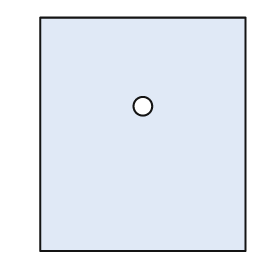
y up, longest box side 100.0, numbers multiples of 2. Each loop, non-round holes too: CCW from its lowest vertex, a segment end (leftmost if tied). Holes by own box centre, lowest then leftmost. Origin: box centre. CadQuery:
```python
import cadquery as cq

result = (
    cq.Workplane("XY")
    .moveTo(-44.0, -50.0)
    .lineTo(44.0, -50.0)
    .lineTo(44.0, 50.0)
    .lineTo(-44.0, 50.0)
    .close()
    .moveTo(0.0, 12.0)
    .circle(4.0)
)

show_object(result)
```